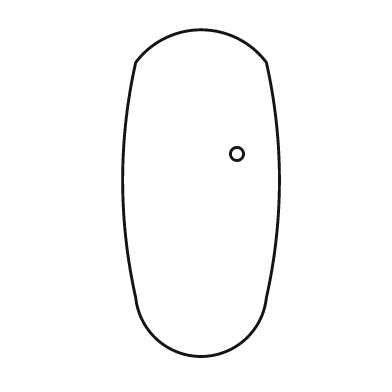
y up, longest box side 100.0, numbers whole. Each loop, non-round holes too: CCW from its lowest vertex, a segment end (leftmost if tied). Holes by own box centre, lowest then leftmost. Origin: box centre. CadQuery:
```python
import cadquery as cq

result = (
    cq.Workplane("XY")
    .moveTo(-20.0, -32.0)
    .threePointArc((0.0, -50.0), (20.0, -32.0))
    .threePointArc((24.0, 4.0), (20.0, 40.0))
    .threePointArc((0.0, 50.0), (-20.0, 40.0))
    .threePointArc((-24.0, 4.0), (-20.0, -32.0))
    .close()
    .moveTo(11.0, 12.0)
    .circle(2.0)
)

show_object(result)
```